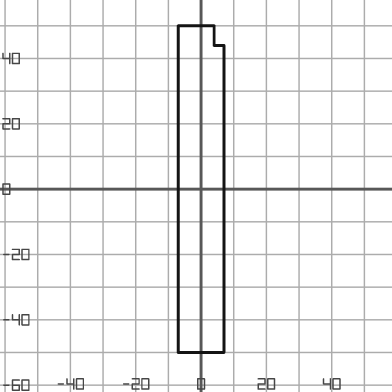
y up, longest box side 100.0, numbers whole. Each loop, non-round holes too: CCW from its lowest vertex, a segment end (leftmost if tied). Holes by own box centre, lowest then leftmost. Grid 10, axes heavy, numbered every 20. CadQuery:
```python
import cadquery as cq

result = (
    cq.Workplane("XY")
    .moveTo(-7.0, -50.0)
    .lineTo(7.0, -50.0)
    .lineTo(7.0, 44.0)
    .lineTo(4.0, 44.0)
    .lineTo(4.0, 50.0)
    .lineTo(-7.0, 50.0)
    .close()
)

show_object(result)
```